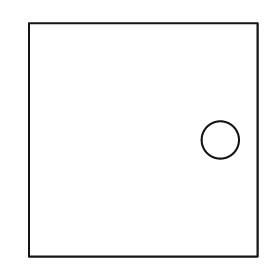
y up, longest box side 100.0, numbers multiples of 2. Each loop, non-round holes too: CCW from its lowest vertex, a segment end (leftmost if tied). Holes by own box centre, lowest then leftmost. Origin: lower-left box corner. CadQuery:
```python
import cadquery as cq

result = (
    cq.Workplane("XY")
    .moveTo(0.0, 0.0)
    .lineTo(98.0, 0.0)
    .lineTo(98.0, 100.0)
    .lineTo(0.0, 100.0)
    .close()
    .moveTo(82.0, 50.0)
    .circle(8.0)
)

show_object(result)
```